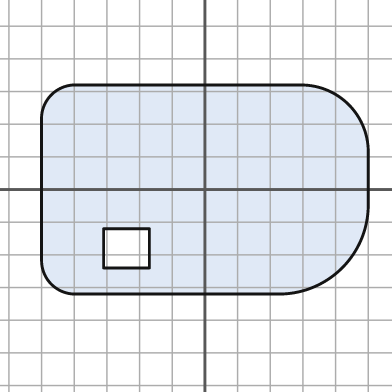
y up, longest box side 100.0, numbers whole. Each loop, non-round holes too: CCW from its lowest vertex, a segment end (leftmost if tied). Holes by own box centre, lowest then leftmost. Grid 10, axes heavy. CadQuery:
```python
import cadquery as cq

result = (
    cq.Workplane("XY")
    .moveTo(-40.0, -32.0)
    .lineTo(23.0, -32.0)
    .threePointArc((42.0, -24.0), (50.0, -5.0))
    .lineTo(50.0, 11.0)
    .threePointArc((44.0, 26.0), (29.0, 32.0))
    .lineTo(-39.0, 32.0)
    .threePointArc((-47.0, 29.0), (-50.0, 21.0))
    .lineTo(-50.0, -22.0)
    .threePointArc((-47.0, -29.0), (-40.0, -32.0))
    .close()
    .moveTo(-31.0, -24.0)
    .lineTo(-17.0, -24.0)
    .lineTo(-17.0, -12.0)
    .lineTo(-31.0, -12.0)
    .close()
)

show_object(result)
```